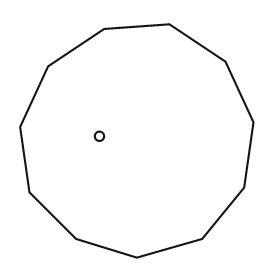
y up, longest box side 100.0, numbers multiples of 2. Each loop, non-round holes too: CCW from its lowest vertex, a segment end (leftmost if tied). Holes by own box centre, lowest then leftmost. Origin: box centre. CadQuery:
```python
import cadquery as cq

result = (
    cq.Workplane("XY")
    .moveTo(0.0, -50.0)
    .lineTo(28.0, -42.0)
    .lineTo(46.0, -20.0)
    .lineTo(50.0, 8.0)
    .lineTo(38.0, 34.0)
    .lineTo(14.0, 50.0)
    .lineTo(-14.0, 48.0)
    .lineTo(-38.0, 32.0)
    .lineTo(-50.0, 6.0)
    .lineTo(-46.0, -22.0)
    .lineTo(-26.0, -42.0)
    .close()
    .moveTo(-16.0, 2.0)
    .circle(2.0)
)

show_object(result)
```